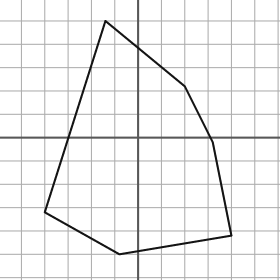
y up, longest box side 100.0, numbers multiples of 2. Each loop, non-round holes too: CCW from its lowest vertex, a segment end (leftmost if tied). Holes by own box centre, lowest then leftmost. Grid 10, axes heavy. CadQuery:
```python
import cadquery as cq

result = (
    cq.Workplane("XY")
    .moveTo(-8.0, -50.0)
    .lineTo(40.0, -42.0)
    .lineTo(32.0, -2.0)
    .lineTo(20.0, 22.0)
    .lineTo(-14.0, 50.0)
    .lineTo(-40.0, -32.0)
    .close()
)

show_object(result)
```